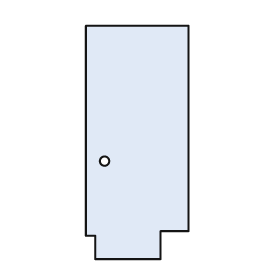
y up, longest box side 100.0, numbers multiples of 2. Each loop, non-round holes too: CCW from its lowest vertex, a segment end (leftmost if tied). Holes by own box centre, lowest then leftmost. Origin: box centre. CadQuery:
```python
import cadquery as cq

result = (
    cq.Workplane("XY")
    .moveTo(-18.0, -50.0)
    .lineTo(10.0, -50.0)
    .lineTo(10.0, -38.0)
    .lineTo(22.0, -38.0)
    .lineTo(22.0, 50.0)
    .lineTo(-22.0, 50.0)
    .lineTo(-22.0, -40.0)
    .lineTo(-18.0, -40.0)
    .close()
    .moveTo(-14.0, -8.0)
    .circle(2.0)
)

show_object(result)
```